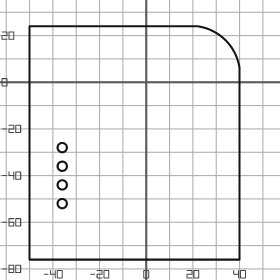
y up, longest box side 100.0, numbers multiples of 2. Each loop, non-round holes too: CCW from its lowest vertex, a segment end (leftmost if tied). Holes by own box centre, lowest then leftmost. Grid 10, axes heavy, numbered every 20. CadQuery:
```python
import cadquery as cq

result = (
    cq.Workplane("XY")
    .moveTo(-50.0, -76.0)
    .lineTo(40.0, -76.0)
    .lineTo(40.0, 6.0)
    .threePointArc((34.0, 18.0), (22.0, 24.0))
    .lineTo(-50.0, 24.0)
    .close()
    .moveTo(-36.0, -52.0)
    .circle(2.0)
    .moveTo(-36.0, -44.0)
    .circle(2.0)
    .moveTo(-36.0, -36.0)
    .circle(2.0)
    .moveTo(-36.0, -28.0)
    .circle(2.0)
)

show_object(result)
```